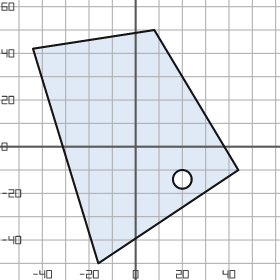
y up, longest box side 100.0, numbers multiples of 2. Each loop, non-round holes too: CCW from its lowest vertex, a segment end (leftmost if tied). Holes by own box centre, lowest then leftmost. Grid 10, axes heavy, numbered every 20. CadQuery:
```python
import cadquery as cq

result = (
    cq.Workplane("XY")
    .moveTo(-16.0, -50.0)
    .lineTo(44.0, -10.0)
    .lineTo(8.0, 50.0)
    .lineTo(-44.0, 42.0)
    .close()
    .moveTo(20.0, -14.0)
    .circle(4.0)
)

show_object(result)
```